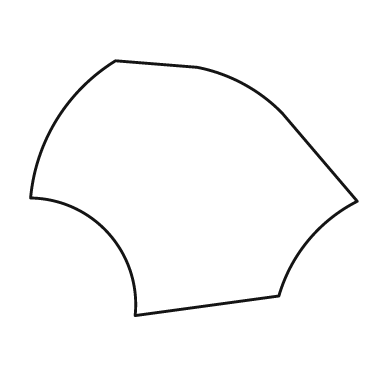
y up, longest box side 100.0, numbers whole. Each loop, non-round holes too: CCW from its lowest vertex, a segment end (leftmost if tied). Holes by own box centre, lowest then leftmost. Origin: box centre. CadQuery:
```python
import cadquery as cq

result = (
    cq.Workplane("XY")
    .moveTo(-18.0, -39.0)
    .lineTo(26.0, -33.0)
    .threePointArc((35.0, -16.0), (50.0, -4.0))
    .lineTo(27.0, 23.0)
    .threePointArc((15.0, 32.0), (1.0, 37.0))
    .lineTo(-24.0, 39.0)
    .threePointArc((-42.0, 21.0), (-50.0, -3.0))
    .threePointArc((-26.0, -14.0), (-18.0, -39.0))
    .close()
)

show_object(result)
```